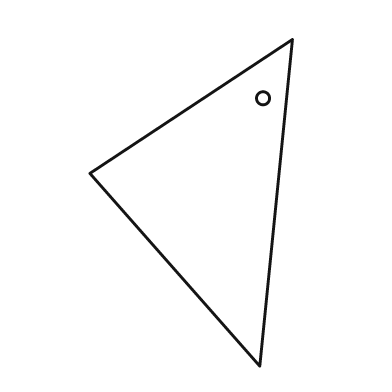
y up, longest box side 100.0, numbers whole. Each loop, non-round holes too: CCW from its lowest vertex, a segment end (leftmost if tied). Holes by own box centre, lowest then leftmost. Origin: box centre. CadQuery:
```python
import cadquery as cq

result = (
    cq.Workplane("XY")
    .moveTo(21.0, -50.0)
    .lineTo(31.0, 50.0)
    .lineTo(-31.0, 9.0)
    .close()
    .moveTo(22.0, 32.0)
    .circle(2.0)
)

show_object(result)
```